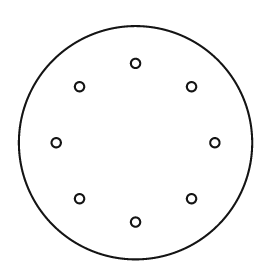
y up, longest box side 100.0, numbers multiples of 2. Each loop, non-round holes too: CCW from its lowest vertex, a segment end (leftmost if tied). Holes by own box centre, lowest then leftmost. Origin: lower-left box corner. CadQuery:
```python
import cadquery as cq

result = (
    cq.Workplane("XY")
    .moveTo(50.0, 50.0)
    .circle(50.0)
    .moveTo(50.0, 16.0)
    .circle(2.0)
    .moveTo(26.0, 26.0)
    .circle(2.0)
    .moveTo(74.0, 26.0)
    .circle(2.0)
    .moveTo(16.0, 50.0)
    .circle(2.0)
    .moveTo(84.0, 50.0)
    .circle(2.0)
    .moveTo(26.0, 74.0)
    .circle(2.0)
    .moveTo(74.0, 74.0)
    .circle(2.0)
    .moveTo(50.0, 84.0)
    .circle(2.0)
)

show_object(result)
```